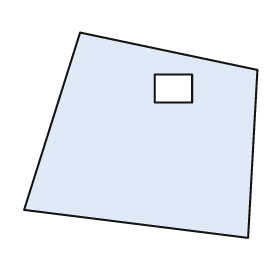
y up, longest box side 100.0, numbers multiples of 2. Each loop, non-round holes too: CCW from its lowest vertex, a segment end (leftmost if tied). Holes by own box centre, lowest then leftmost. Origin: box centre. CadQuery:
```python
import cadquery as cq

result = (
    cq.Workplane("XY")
    .moveTo(46.0, -44.0)
    .lineTo(50.0, 28.0)
    .lineTo(-26.0, 44.0)
    .lineTo(-50.0, -32.0)
    .close()
    .moveTo(6.0, 14.0)
    .lineTo(22.0, 14.0)
    .lineTo(22.0, 26.0)
    .lineTo(6.0, 26.0)
    .close()
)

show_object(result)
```